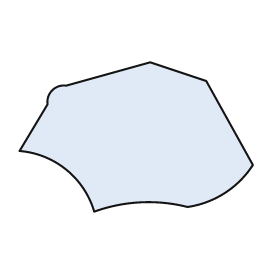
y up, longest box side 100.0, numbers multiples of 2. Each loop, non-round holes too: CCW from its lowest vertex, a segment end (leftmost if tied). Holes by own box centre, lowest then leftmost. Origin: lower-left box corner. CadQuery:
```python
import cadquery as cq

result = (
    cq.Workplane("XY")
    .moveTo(32.0, 0.0)
    .threePointArc((52.0, 4.0), (72.0, 2.0))
    .threePointArc((88.0, 8.0), (100.0, 20.0))
    .lineTo(80.0, 56.0)
    .lineTo(56.0, 64.0)
    .lineTo(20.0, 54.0)
    .threePointArc((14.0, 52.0), (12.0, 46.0))
    .lineTo(0.0, 26.0)
    .threePointArc((20.0, 18.0), (32.0, 0.0))
    .close()
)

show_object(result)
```